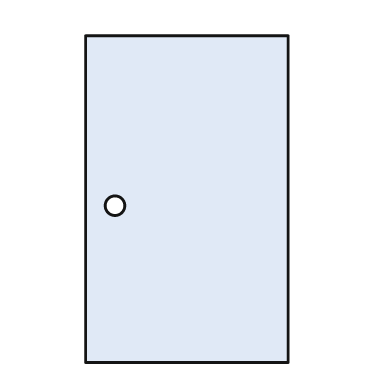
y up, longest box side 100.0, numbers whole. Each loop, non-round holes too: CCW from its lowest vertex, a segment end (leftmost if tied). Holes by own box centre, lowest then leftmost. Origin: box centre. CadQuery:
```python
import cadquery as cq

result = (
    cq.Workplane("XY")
    .moveTo(-31.0, -50.0)
    .lineTo(31.0, -50.0)
    .lineTo(31.0, 50.0)
    .lineTo(-31.0, 50.0)
    .close()
    .moveTo(-22.0, -2.0)
    .circle(3.0)
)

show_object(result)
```